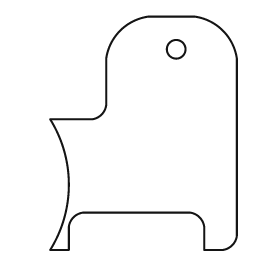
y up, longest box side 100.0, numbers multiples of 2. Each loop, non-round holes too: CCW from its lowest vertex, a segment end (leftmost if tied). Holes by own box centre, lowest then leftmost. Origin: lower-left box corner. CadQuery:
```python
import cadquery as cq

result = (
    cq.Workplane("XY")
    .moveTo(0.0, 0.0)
    .lineTo(8.0, 0.0)
    .lineTo(8.0, 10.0)
    .threePointArc((10.0, 14.0), (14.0, 16.0))
    .lineTo(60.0, 16.0)
    .threePointArc((64.0, 14.0), (66.0, 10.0))
    .lineTo(66.0, 0.0)
    .lineTo(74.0, 0.0)
    .threePointArc((78.0, 2.0), (80.0, 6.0))
    .lineTo(80.0, 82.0)
    .threePointArc((74.0, 94.0), (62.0, 100.0))
    .lineTo(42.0, 100.0)
    .threePointArc((30.0, 94.0), (24.0, 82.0))
    .lineTo(24.0, 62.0)
    .threePointArc((22.0, 58.0), (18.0, 56.0))
    .lineTo(0.0, 56.0)
    .threePointArc((8.0, 28.0), (0.0, 0.0))
    .close()
    .moveTo(54.0, 86.0)
    .circle(4.0)
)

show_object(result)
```